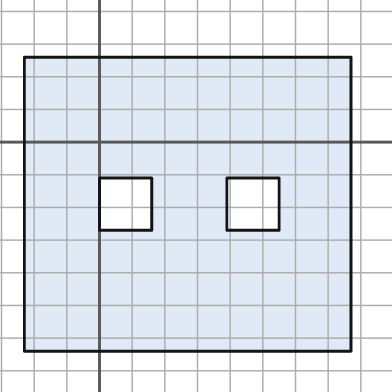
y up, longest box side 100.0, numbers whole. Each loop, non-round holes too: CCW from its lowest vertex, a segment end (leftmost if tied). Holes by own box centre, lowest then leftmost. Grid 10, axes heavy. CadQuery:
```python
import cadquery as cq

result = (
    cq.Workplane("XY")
    .moveTo(-23.0, -64.0)
    .lineTo(77.0, -64.0)
    .lineTo(77.0, 26.0)
    .lineTo(-23.0, 26.0)
    .close()
    .moveTo(0.0, -27.0)
    .lineTo(16.0, -27.0)
    .lineTo(16.0, -11.0)
    .lineTo(0.0, -11.0)
    .close()
    .moveTo(39.0, -27.0)
    .lineTo(55.0, -27.0)
    .lineTo(55.0, -11.0)
    .lineTo(39.0, -11.0)
    .close()
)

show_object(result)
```